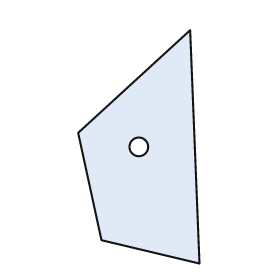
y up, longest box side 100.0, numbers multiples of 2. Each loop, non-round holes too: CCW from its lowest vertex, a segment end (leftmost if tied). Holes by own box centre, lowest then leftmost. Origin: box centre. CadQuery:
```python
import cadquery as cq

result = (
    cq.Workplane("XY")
    .moveTo(26.0, -50.0)
    .lineTo(22.0, 50.0)
    .lineTo(-26.0, 6.0)
    .lineTo(-16.0, -40.0)
    .close()
    .moveTo(0.0, 0.0)
    .circle(4.0)
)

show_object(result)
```